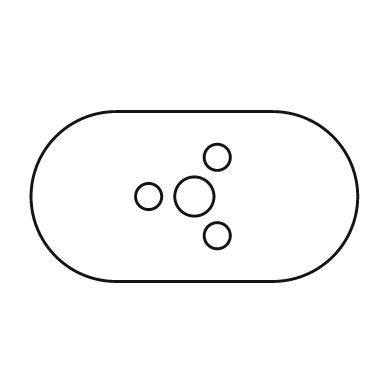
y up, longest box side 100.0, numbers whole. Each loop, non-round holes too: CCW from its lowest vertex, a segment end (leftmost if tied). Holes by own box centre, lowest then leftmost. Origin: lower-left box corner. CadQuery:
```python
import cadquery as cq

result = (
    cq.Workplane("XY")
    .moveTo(26.0, 0.0)
    .lineTo(74.0, 0.0)
    .threePointArc((100.0, 26.0), (74.0, 52.0))
    .lineTo(26.0, 52.0)
    .threePointArc((0.0, 26.0), (26.0, 0.0))
    .close()
    .moveTo(57.0, 14.0)
    .circle(4.0)
    .moveTo(36.0, 26.0)
    .circle(4.0)
    .moveTo(50.0, 26.0)
    .circle(6.0)
    .moveTo(57.0, 38.0)
    .circle(4.0)
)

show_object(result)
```